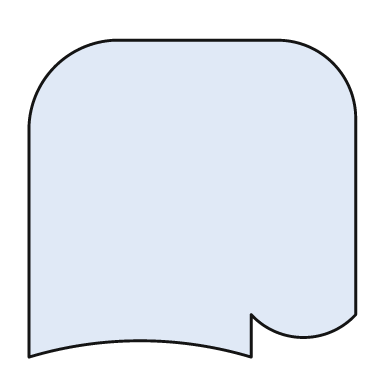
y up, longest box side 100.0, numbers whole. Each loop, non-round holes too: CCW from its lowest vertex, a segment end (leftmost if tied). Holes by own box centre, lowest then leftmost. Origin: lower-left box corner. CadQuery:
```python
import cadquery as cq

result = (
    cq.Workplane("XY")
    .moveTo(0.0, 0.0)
    .threePointArc((34.0, 5.0), (68.0, 0.0))
    .lineTo(68.0, 13.0)
    .threePointArc((84.0, 6.0), (100.0, 13.0))
    .lineTo(100.0, 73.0)
    .threePointArc((93.0, 90.0), (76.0, 97.0))
    .lineTo(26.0, 97.0)
    .threePointArc((8.0, 89.0), (0.0, 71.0))
    .close()
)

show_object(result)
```